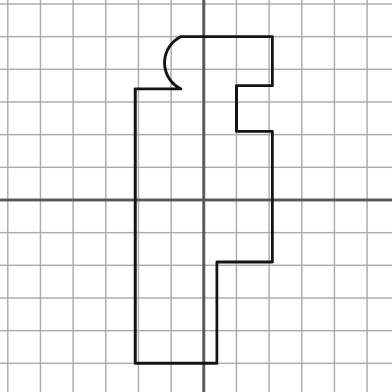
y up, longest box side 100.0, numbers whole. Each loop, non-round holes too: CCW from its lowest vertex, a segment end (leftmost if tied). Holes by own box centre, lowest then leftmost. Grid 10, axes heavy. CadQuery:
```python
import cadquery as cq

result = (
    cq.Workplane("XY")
    .moveTo(-21.0, -50.0)
    .lineTo(4.0, -50.0)
    .lineTo(4.0, -19.0)
    .lineTo(21.0, -19.0)
    .lineTo(21.0, 21.0)
    .lineTo(10.0, 21.0)
    .lineTo(10.0, 35.0)
    .lineTo(21.0, 35.0)
    .lineTo(21.0, 50.0)
    .lineTo(-7.0, 50.0)
    .threePointArc((-12.0, 42.0), (-7.0, 34.0))
    .lineTo(-21.0, 34.0)
    .close()
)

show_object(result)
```